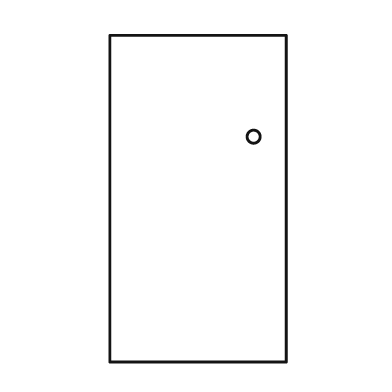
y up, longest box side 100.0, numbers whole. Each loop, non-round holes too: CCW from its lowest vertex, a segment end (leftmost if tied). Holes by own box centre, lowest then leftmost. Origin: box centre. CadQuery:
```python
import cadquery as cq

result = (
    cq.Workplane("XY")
    .moveTo(-27.0, -50.0)
    .lineTo(27.0, -50.0)
    .lineTo(27.0, 50.0)
    .lineTo(-27.0, 50.0)
    .close()
    .moveTo(17.0, 19.0)
    .circle(2.0)
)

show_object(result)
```